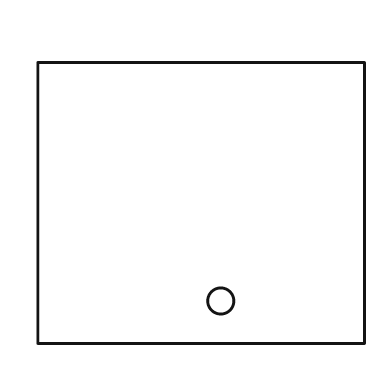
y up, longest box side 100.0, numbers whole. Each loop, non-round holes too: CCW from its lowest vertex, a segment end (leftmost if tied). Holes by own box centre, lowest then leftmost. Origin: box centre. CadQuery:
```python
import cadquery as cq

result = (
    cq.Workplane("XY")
    .moveTo(-50.0, -43.0)
    .lineTo(50.0, -43.0)
    .lineTo(50.0, 43.0)
    .lineTo(-50.0, 43.0)
    .close()
    .moveTo(6.0, -30.0)
    .circle(4.0)
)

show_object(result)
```